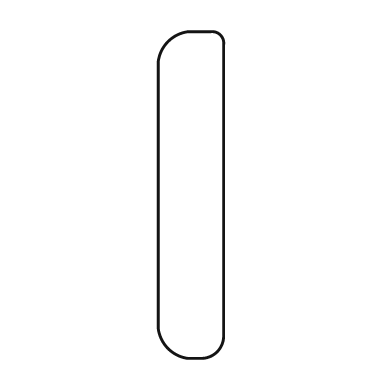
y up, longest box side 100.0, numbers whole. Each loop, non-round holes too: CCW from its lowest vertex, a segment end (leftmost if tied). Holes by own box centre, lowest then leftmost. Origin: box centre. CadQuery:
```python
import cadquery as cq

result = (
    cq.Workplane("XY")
    .moveTo(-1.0, -50.0)
    .lineTo(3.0, -50.0)
    .threePointArc((8.0, -48.0), (10.0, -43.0))
    .lineTo(10.0, 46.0)
    .threePointArc((9.0, 49.0), (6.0, 50.0))
    .lineTo(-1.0, 50.0)
    .threePointArc((-7.0, 47.0), (-10.0, 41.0))
    .lineTo(-10.0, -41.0)
    .threePointArc((-7.0, -47.0), (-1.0, -50.0))
    .close()
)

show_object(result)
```